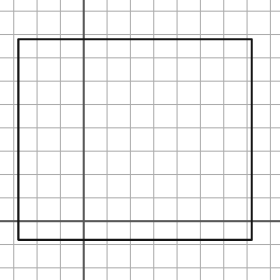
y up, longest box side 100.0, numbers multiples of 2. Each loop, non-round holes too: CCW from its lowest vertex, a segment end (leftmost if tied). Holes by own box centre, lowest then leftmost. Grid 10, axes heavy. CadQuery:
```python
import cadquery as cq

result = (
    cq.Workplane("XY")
    .moveTo(-28.0, -8.0)
    .lineTo(72.0, -8.0)
    .lineTo(72.0, 78.0)
    .lineTo(-28.0, 78.0)
    .close()
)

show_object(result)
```